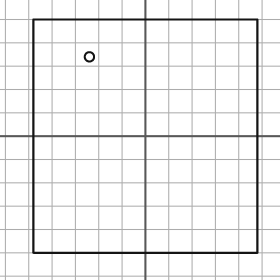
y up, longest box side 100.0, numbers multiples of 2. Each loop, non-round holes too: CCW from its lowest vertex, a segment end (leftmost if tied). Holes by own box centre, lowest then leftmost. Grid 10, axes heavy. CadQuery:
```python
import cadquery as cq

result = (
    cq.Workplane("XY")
    .moveTo(-48.0, -50.0)
    .lineTo(48.0, -50.0)
    .lineTo(48.0, 50.0)
    .lineTo(-48.0, 50.0)
    .close()
    .moveTo(-24.0, 34.0)
    .circle(2.0)
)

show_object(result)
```